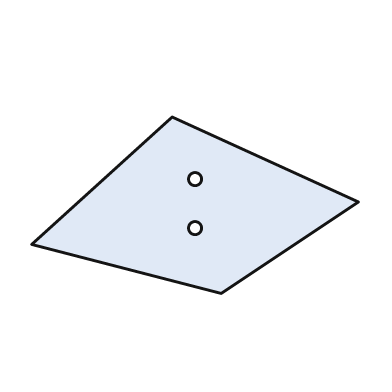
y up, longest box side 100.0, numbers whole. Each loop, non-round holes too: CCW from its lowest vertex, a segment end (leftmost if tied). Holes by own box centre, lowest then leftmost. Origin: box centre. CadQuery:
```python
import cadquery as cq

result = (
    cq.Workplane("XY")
    .moveTo(8.0, -27.0)
    .lineTo(50.0, 1.0)
    .lineTo(-7.0, 27.0)
    .lineTo(-50.0, -12.0)
    .close()
    .moveTo(0.0, -7.0)
    .circle(2.0)
    .moveTo(0.0, 8.0)
    .circle(2.0)
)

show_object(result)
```